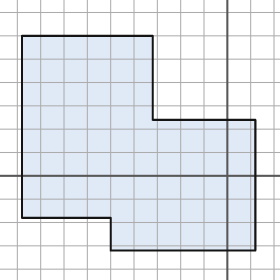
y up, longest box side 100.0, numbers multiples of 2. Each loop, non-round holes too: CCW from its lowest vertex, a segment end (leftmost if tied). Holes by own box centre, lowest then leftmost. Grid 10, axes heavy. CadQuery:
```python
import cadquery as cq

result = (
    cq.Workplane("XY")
    .moveTo(-50.0, -32.0)
    .lineTo(12.0, -32.0)
    .lineTo(12.0, 24.0)
    .lineTo(-32.0, 24.0)
    .lineTo(-32.0, 60.0)
    .lineTo(-88.0, 60.0)
    .lineTo(-88.0, -18.0)
    .lineTo(-50.0, -18.0)
    .close()
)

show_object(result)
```